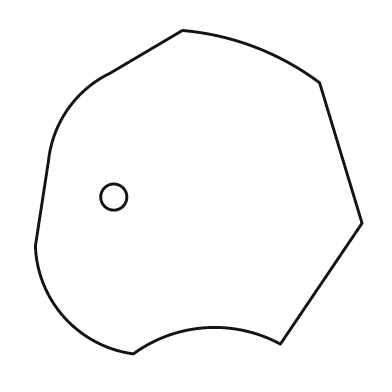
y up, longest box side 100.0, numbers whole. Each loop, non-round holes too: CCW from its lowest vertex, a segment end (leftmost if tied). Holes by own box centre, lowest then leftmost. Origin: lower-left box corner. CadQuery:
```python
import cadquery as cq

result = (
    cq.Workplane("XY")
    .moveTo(30.0, 0.0)
    .threePointArc((52.0, 8.0), (75.0, 3.0))
    .lineTo(100.0, 40.0)
    .lineTo(87.0, 83.0)
    .threePointArc((67.0, 94.0), (45.0, 99.0))
    .lineTo(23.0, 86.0)
    .threePointArc((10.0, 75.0), (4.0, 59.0))
    .lineTo(0.0, 33.0)
    .threePointArc((9.0, 11.0), (30.0, 0.0))
    .close()
    .moveTo(24.0, 48.0)
    .circle(4.0)
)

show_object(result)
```